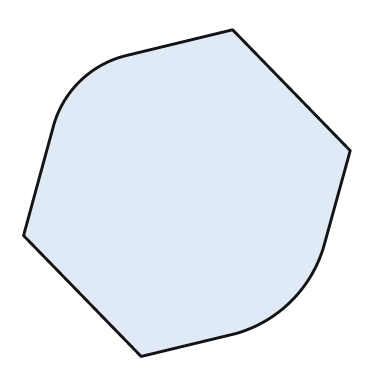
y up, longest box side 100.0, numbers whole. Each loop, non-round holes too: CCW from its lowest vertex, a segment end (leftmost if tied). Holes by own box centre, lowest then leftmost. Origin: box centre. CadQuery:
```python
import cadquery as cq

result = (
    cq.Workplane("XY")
    .moveTo(-14.0, -50.0)
    .lineTo(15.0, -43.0)
    .threePointArc((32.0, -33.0), (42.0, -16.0))
    .lineTo(50.0, 13.0)
    .lineTo(14.0, 50.0)
    .lineTo(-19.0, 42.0)
    .threePointArc((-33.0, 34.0), (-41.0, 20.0))
    .lineTo(-50.0, -13.0)
    .close()
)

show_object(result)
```